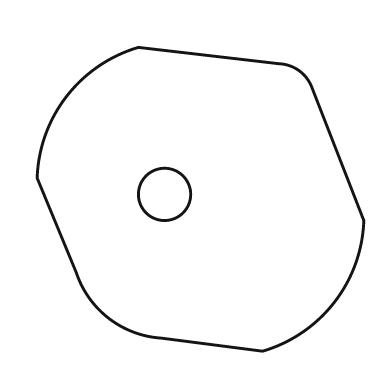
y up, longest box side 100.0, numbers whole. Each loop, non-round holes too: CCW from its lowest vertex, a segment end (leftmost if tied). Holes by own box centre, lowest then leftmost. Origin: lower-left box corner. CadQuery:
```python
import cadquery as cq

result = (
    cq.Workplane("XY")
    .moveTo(69.0, 0.0)
    .threePointArc((91.0, 15.0), (100.0, 40.0))
    .lineTo(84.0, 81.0)
    .threePointArc((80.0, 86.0), (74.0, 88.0))
    .lineTo(31.0, 93.0)
    .threePointArc((9.0, 78.0), (0.0, 53.0))
    .lineTo(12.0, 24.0)
    .threePointArc((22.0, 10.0), (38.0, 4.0))
    .close()
    .moveTo(39.0, 48.0)
    .circle(8.0)
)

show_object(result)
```